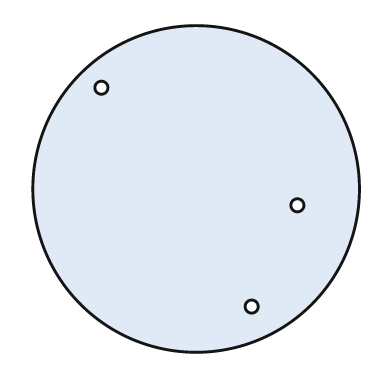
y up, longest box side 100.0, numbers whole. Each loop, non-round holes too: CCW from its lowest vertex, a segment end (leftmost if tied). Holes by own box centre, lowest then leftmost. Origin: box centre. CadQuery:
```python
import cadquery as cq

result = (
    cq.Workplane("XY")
    .moveTo(0.0, 0.0)
    .circle(50.0)
    .moveTo(17.0, -36.0)
    .circle(2.0)
    .moveTo(31.0, -5.0)
    .circle(2.0)
    .moveTo(-29.0, 31.0)
    .circle(2.0)
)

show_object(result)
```